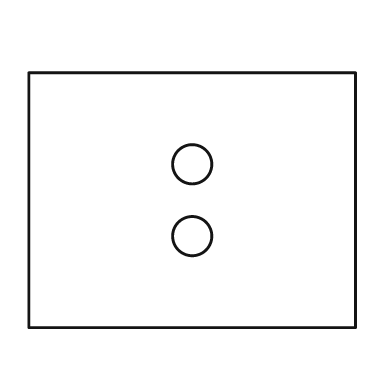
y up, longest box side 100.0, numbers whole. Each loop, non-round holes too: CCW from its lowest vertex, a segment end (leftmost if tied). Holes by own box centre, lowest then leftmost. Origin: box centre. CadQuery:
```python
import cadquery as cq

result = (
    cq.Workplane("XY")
    .moveTo(-50.0, -39.0)
    .lineTo(50.0, -39.0)
    .lineTo(50.0, 39.0)
    .lineTo(-50.0, 39.0)
    .close()
    .moveTo(0.0, -11.0)
    .circle(6.0)
    .moveTo(0.0, 11.0)
    .circle(6.0)
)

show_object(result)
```